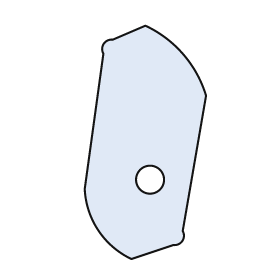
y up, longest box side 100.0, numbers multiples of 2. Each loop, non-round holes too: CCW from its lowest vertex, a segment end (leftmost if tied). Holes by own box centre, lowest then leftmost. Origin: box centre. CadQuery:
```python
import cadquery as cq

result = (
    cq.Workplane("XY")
    .moveTo(-6.0, -50.0)
    .lineTo(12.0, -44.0)
    .threePointArc((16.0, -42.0), (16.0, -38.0))
    .lineTo(26.0, 20.0)
    .threePointArc((16.0, 38.0), (0.0, 50.0))
    .lineTo(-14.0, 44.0)
    .threePointArc((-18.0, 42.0), (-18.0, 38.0))
    .lineTo(-26.0, -20.0)
    .threePointArc((-20.0, -38.0), (-6.0, -50.0))
    .close()
    .moveTo(2.0, -16.0)
    .circle(6.0)
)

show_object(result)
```